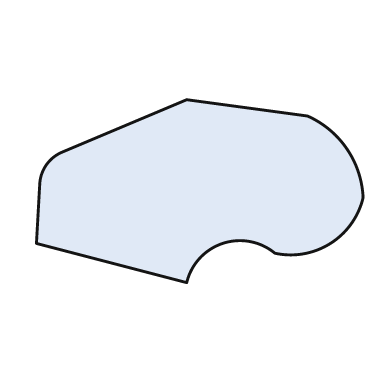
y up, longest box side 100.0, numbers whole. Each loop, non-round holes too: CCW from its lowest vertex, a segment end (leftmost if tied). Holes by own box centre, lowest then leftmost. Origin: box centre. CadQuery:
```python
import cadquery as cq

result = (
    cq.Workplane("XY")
    .moveTo(-4.0, -28.0)
    .threePointArc((7.0, -16.0), (23.0, -19.0))
    .threePointArc((40.0, -16.0), (50.0, -2.0))
    .threePointArc((45.0, 13.0), (33.0, 23.0))
    .lineTo(-4.0, 28.0)
    .lineTo(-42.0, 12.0)
    .threePointArc((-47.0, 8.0), (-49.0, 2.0))
    .lineTo(-50.0, -16.0)
    .close()
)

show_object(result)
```